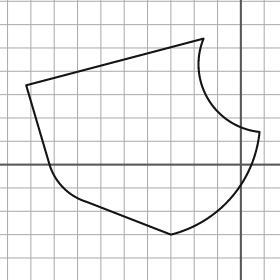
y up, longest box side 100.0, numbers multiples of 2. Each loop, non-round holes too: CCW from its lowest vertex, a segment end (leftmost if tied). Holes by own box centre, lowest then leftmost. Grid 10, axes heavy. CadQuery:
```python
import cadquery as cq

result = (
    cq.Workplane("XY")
    .moveTo(-30.0, -30.0)
    .threePointArc((-4.0, -14.0), (8.0, 14.0))
    .threePointArc((-14.0, 28.0), (-16.0, 54.0))
    .lineTo(-92.0, 34.0)
    .lineTo(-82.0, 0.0)
    .threePointArc((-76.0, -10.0), (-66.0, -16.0))
    .close()
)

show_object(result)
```